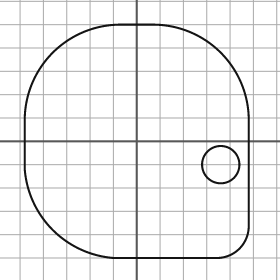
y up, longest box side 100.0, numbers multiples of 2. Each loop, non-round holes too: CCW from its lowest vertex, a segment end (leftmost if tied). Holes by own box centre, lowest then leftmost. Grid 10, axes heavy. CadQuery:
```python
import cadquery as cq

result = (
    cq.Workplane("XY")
    .moveTo(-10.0, -50.0)
    .lineTo(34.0, -50.0)
    .threePointArc((44.0, -46.0), (48.0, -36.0))
    .lineTo(48.0, 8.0)
    .threePointArc((36.0, 38.0), (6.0, 50.0))
    .lineTo(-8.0, 50.0)
    .threePointArc((-36.0, 38.0), (-48.0, 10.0))
    .lineTo(-48.0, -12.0)
    .threePointArc((-36.0, -38.0), (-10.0, -50.0))
    .close()
    .moveTo(36.0, -10.0)
    .circle(8.0)
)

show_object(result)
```